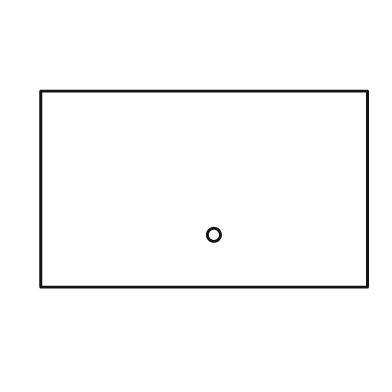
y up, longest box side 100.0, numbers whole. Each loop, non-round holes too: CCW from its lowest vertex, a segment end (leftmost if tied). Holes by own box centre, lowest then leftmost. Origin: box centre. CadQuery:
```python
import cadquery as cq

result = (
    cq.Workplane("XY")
    .moveTo(-50.0, -30.0)
    .lineTo(50.0, -30.0)
    .lineTo(50.0, 30.0)
    .lineTo(-50.0, 30.0)
    .close()
    .moveTo(3.0, -14.0)
    .circle(2.0)
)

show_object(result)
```